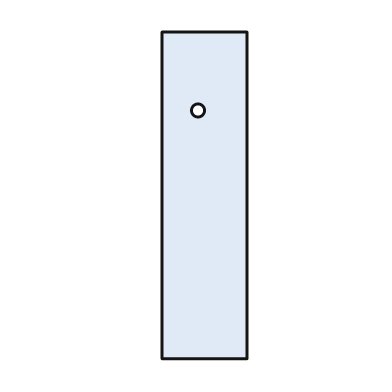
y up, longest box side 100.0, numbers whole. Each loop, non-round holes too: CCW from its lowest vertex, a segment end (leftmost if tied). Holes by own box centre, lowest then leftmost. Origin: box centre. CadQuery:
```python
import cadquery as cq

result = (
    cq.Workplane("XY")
    .moveTo(-13.0, -50.0)
    .lineTo(13.0, -50.0)
    .lineTo(13.0, 50.0)
    .lineTo(-13.0, 50.0)
    .close()
    .moveTo(-2.0, 26.0)
    .circle(2.0)
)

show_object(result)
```